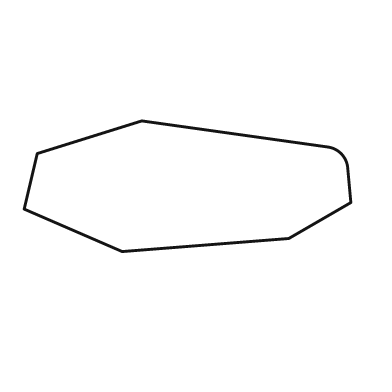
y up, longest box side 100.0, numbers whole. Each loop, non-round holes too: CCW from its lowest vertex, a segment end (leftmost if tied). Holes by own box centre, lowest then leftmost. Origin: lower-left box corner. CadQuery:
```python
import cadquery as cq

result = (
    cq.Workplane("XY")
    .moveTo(30.0, 0.0)
    .lineTo(81.0, 4.0)
    .lineTo(100.0, 15.0)
    .lineTo(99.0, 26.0)
    .threePointArc((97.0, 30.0), (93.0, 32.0))
    .lineTo(36.0, 40.0)
    .lineTo(4.0, 30.0)
    .lineTo(0.0, 13.0)
    .close()
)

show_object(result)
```